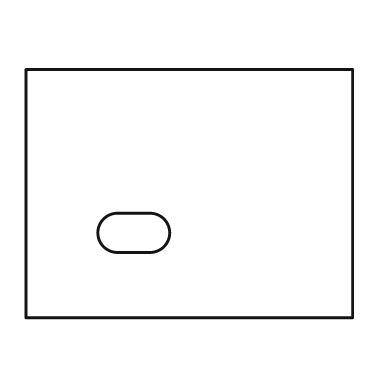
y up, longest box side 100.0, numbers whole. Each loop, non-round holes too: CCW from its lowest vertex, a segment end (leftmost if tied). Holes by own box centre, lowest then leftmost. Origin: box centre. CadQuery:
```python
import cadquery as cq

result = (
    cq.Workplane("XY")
    .moveTo(-50.0, -38.0)
    .lineTo(50.0, -38.0)
    .lineTo(50.0, 38.0)
    .lineTo(-50.0, 38.0)
    .close()
    .moveTo(-22.0, -18.0)
    .lineTo(-12.0, -18.0)
    .threePointArc((-6.0, -12.0), (-12.0, -6.0))
    .lineTo(-22.0, -6.0)
    .threePointArc((-28.0, -12.0), (-22.0, -18.0))
    .close()
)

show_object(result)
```